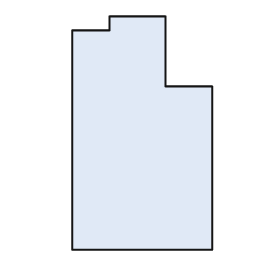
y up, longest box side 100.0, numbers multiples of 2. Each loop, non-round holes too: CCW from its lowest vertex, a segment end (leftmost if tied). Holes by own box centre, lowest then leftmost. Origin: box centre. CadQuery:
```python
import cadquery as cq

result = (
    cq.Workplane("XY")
    .moveTo(-30.0, -50.0)
    .lineTo(30.0, -50.0)
    .lineTo(30.0, 20.0)
    .lineTo(10.0, 20.0)
    .lineTo(10.0, 50.0)
    .lineTo(-14.0, 50.0)
    .lineTo(-14.0, 44.0)
    .lineTo(-30.0, 44.0)
    .close()
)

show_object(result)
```